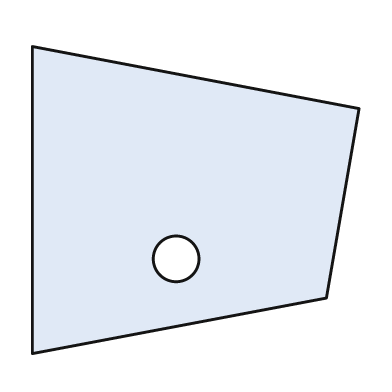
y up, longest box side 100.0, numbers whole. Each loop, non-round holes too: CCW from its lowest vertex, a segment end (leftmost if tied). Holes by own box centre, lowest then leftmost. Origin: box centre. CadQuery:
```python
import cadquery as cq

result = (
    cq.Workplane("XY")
    .moveTo(-50.0, -47.0)
    .lineTo(40.0, -30.0)
    .lineTo(50.0, 28.0)
    .lineTo(-50.0, 47.0)
    .close()
    .moveTo(-6.0, -18.0)
    .circle(7.0)
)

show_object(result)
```